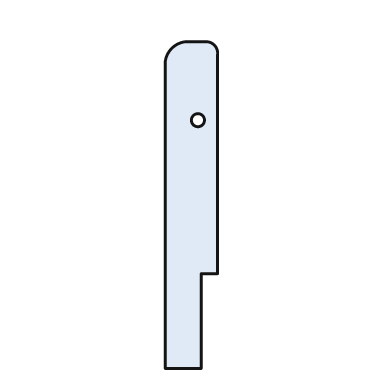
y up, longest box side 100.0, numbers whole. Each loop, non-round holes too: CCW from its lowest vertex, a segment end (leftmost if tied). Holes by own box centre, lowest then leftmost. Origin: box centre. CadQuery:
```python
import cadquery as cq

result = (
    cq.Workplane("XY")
    .moveTo(-8.0, -50.0)
    .lineTo(3.0, -50.0)
    .lineTo(3.0, -21.0)
    .lineTo(8.0, -21.0)
    .lineTo(8.0, 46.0)
    .threePointArc((7.0, 49.0), (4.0, 50.0))
    .lineTo(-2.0, 50.0)
    .threePointArc((-6.0, 48.0), (-8.0, 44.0))
    .close()
    .moveTo(2.0, 26.0)
    .circle(2.0)
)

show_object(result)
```